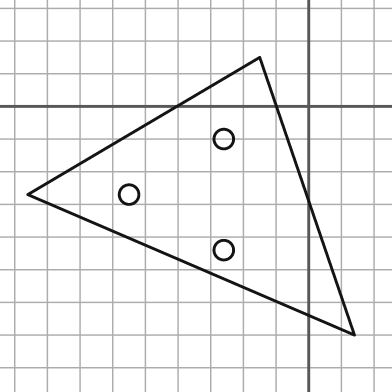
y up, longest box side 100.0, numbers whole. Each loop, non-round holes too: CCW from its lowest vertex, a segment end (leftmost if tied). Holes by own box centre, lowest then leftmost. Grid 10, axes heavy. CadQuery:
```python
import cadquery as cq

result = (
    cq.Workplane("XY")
    .moveTo(14.0, -70.0)
    .lineTo(-15.0, 15.0)
    .lineTo(-86.0, -27.0)
    .close()
    .moveTo(-26.0, -44.0)
    .circle(3.0)
    .moveTo(-55.0, -27.0)
    .circle(3.0)
    .moveTo(-26.0, -10.0)
    .circle(3.0)
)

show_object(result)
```